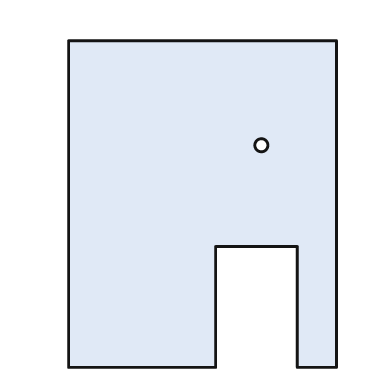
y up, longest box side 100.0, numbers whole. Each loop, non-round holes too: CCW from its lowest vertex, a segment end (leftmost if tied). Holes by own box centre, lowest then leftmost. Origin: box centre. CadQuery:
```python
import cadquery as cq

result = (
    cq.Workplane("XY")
    .moveTo(-41.0, -50.0)
    .lineTo(4.0, -50.0)
    .lineTo(4.0, -13.0)
    .lineTo(29.0, -13.0)
    .lineTo(29.0, -50.0)
    .lineTo(41.0, -50.0)
    .lineTo(41.0, 50.0)
    .lineTo(-41.0, 50.0)
    .close()
    .moveTo(18.0, 18.0)
    .circle(2.0)
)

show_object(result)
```